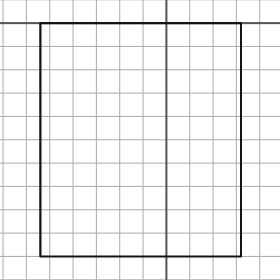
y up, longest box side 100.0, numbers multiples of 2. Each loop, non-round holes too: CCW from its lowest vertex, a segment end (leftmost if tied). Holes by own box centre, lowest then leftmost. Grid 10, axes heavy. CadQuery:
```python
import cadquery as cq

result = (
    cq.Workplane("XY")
    .moveTo(-54.0, -100.0)
    .lineTo(32.0, -100.0)
    .lineTo(32.0, 0.0)
    .lineTo(-54.0, 0.0)
    .close()
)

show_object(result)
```